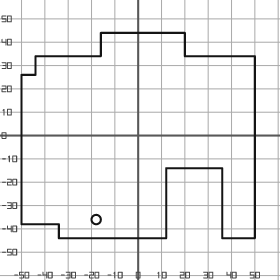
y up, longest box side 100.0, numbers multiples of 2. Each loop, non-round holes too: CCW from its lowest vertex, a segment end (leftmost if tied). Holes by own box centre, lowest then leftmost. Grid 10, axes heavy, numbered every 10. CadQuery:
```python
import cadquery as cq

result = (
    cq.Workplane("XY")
    .moveTo(-34.0, -44.0)
    .lineTo(12.0, -44.0)
    .lineTo(12.0, -14.0)
    .lineTo(36.0, -14.0)
    .lineTo(36.0, -44.0)
    .lineTo(50.0, -44.0)
    .lineTo(50.0, 34.0)
    .lineTo(20.0, 34.0)
    .lineTo(20.0, 44.0)
    .lineTo(-16.0, 44.0)
    .lineTo(-16.0, 34.0)
    .lineTo(-44.0, 34.0)
    .lineTo(-44.0, 26.0)
    .lineTo(-50.0, 26.0)
    .lineTo(-50.0, -38.0)
    .lineTo(-34.0, -38.0)
    .close()
    .moveTo(-18.0, -36.0)
    .circle(2.0)
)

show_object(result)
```